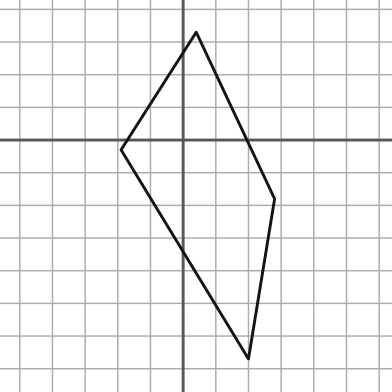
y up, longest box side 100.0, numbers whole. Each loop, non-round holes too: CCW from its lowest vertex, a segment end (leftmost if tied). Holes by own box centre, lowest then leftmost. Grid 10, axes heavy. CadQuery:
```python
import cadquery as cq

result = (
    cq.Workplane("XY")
    .moveTo(20.0, -67.0)
    .lineTo(28.0, -18.0)
    .lineTo(4.0, 33.0)
    .lineTo(-19.0, -3.0)
    .close()
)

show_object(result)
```